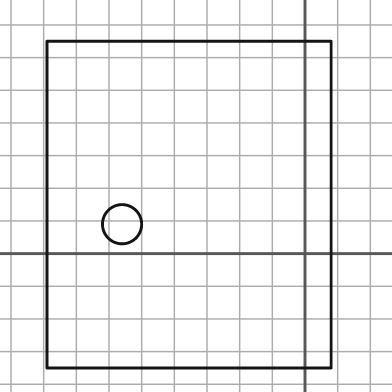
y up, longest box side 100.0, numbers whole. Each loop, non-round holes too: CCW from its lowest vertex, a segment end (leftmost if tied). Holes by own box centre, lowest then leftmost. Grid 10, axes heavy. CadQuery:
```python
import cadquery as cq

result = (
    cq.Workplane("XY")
    .moveTo(-79.0, -35.0)
    .lineTo(8.0, -35.0)
    .lineTo(8.0, 65.0)
    .lineTo(-79.0, 65.0)
    .close()
    .moveTo(-56.0, 9.0)
    .circle(6.0)
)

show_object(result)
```